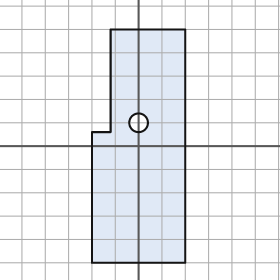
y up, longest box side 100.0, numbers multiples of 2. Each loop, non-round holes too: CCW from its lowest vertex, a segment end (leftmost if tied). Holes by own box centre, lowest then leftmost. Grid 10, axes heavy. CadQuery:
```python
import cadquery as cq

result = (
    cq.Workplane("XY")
    .moveTo(-20.0, -50.0)
    .lineTo(20.0, -50.0)
    .lineTo(20.0, 50.0)
    .lineTo(-12.0, 50.0)
    .lineTo(-12.0, 6.0)
    .lineTo(-20.0, 6.0)
    .close()
    .moveTo(0.0, 10.0)
    .circle(4.0)
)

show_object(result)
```